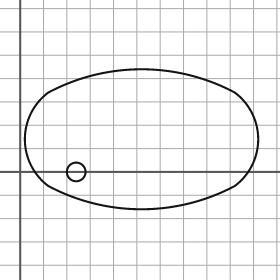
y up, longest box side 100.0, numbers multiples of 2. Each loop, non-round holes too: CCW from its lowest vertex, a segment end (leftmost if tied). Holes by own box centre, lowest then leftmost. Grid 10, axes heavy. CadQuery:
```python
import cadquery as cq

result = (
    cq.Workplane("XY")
    .moveTo(12.0, -6.0)
    .threePointArc((52.0, -16.0), (92.0, -6.0))
    .threePointArc((102.0, 14.0), (92.0, 34.0))
    .threePointArc((52.0, 44.0), (12.0, 34.0))
    .threePointArc((2.0, 14.0), (12.0, -6.0))
    .close()
    .moveTo(24.0, 0.0)
    .circle(4.0)
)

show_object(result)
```